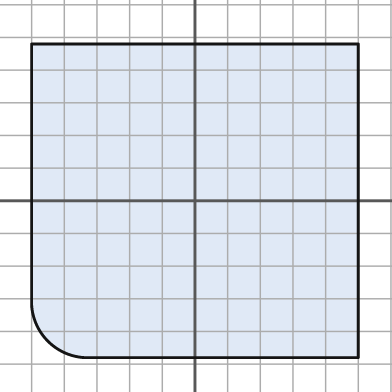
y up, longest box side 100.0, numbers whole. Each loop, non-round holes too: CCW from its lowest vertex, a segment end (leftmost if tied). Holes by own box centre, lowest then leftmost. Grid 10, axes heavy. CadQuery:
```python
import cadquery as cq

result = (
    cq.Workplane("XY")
    .moveTo(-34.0, -48.0)
    .lineTo(50.0, -48.0)
    .lineTo(50.0, 48.0)
    .lineTo(-50.0, 48.0)
    .lineTo(-50.0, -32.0)
    .threePointArc((-45.0, -43.0), (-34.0, -48.0))
    .close()
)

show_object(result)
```